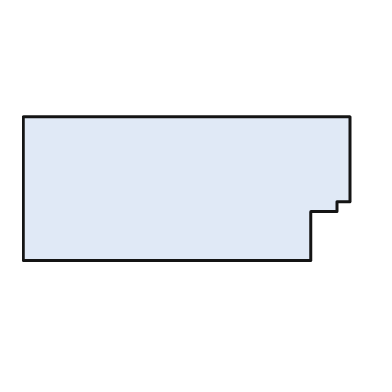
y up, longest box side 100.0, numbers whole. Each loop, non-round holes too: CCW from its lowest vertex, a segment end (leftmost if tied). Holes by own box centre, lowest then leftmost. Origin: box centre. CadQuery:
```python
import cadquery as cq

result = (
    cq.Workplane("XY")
    .moveTo(-50.0, -22.0)
    .lineTo(38.0, -22.0)
    .lineTo(38.0, -7.0)
    .lineTo(46.0, -7.0)
    .lineTo(46.0, -4.0)
    .lineTo(50.0, -4.0)
    .lineTo(50.0, 22.0)
    .lineTo(-50.0, 22.0)
    .close()
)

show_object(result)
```